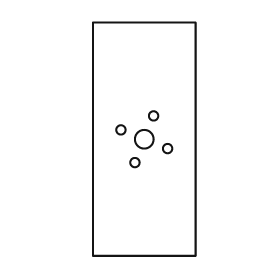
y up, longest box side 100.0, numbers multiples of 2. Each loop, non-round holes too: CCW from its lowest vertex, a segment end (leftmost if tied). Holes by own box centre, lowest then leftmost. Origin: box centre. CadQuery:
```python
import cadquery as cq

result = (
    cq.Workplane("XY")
    .moveTo(-22.0, -50.0)
    .lineTo(22.0, -50.0)
    .lineTo(22.0, 50.0)
    .lineTo(-22.0, 50.0)
    .close()
    .moveTo(-4.0, -10.0)
    .circle(2.0)
    .moveTo(10.0, -4.0)
    .circle(2.0)
    .moveTo(0.0, 0.0)
    .circle(4.0)
    .moveTo(-10.0, 4.0)
    .circle(2.0)
    .moveTo(4.0, 10.0)
    .circle(2.0)
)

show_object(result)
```